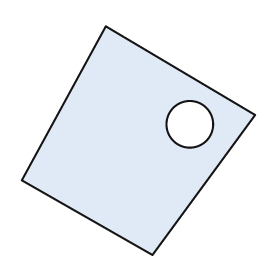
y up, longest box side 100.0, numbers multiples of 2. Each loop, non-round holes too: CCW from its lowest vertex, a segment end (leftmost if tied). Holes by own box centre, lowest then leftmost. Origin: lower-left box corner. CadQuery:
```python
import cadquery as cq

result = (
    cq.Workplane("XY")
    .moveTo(56.0, 0.0)
    .lineTo(100.0, 60.0)
    .lineTo(36.0, 98.0)
    .lineTo(0.0, 32.0)
    .close()
    .moveTo(72.0, 56.0)
    .circle(10.0)
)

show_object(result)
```